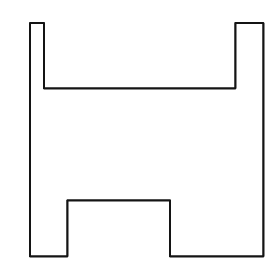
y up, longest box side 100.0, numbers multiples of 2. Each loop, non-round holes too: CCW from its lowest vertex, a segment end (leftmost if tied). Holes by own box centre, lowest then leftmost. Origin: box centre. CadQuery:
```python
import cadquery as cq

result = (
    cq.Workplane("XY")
    .moveTo(-50.0, -50.0)
    .lineTo(-34.0, -50.0)
    .lineTo(-34.0, -26.0)
    .lineTo(10.0, -26.0)
    .lineTo(10.0, -50.0)
    .lineTo(50.0, -50.0)
    .lineTo(50.0, 50.0)
    .lineTo(38.0, 50.0)
    .lineTo(38.0, 22.0)
    .lineTo(-44.0, 22.0)
    .lineTo(-44.0, 50.0)
    .lineTo(-50.0, 50.0)
    .close()
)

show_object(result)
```